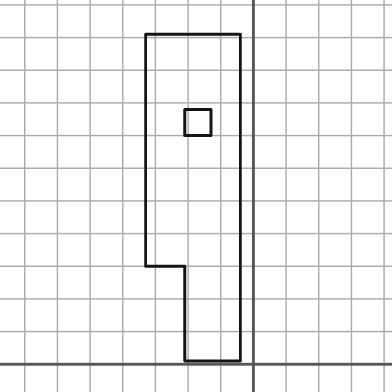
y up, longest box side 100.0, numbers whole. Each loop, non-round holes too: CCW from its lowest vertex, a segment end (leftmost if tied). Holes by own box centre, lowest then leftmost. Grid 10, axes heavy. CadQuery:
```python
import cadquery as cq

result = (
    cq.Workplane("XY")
    .moveTo(-21.0, 1.0)
    .lineTo(-4.0, 1.0)
    .lineTo(-4.0, 101.0)
    .lineTo(-33.0, 101.0)
    .lineTo(-33.0, 30.0)
    .lineTo(-21.0, 30.0)
    .close()
    .moveTo(-21.0, 70.0)
    .lineTo(-13.0, 70.0)
    .lineTo(-13.0, 78.0)
    .lineTo(-21.0, 78.0)
    .close()
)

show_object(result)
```